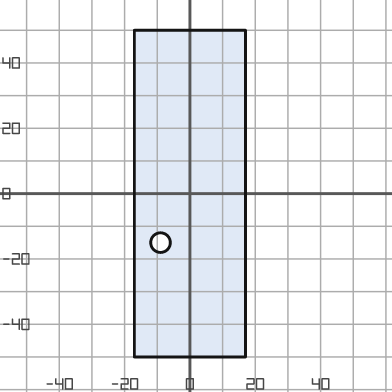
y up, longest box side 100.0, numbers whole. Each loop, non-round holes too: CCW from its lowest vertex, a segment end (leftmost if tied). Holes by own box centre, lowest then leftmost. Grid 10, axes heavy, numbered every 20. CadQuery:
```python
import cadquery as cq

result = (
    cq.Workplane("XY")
    .moveTo(-17.0, -50.0)
    .lineTo(17.0, -50.0)
    .lineTo(17.0, 50.0)
    .lineTo(-17.0, 50.0)
    .close()
    .moveTo(-9.0, -15.0)
    .circle(3.0)
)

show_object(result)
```